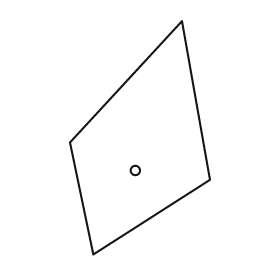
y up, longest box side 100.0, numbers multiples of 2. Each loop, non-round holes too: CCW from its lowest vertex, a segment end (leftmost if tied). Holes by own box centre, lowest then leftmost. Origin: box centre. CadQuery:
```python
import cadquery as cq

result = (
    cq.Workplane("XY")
    .moveTo(-20.0, -50.0)
    .lineTo(30.0, -18.0)
    .lineTo(18.0, 50.0)
    .lineTo(-30.0, -2.0)
    .close()
    .moveTo(-2.0, -14.0)
    .circle(2.0)
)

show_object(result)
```